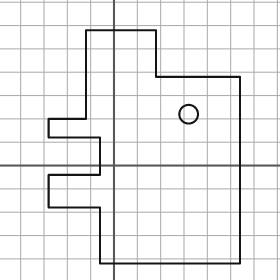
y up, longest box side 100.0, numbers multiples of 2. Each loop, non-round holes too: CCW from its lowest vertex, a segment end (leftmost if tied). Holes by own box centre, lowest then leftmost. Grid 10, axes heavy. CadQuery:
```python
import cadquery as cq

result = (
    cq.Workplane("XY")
    .moveTo(-6.0, -42.0)
    .lineTo(54.0, -42.0)
    .lineTo(54.0, 38.0)
    .lineTo(18.0, 38.0)
    .lineTo(18.0, 58.0)
    .lineTo(-12.0, 58.0)
    .lineTo(-12.0, 20.0)
    .lineTo(-28.0, 20.0)
    .lineTo(-28.0, 12.0)
    .lineTo(-6.0, 12.0)
    .lineTo(-6.0, -4.0)
    .lineTo(-28.0, -4.0)
    .lineTo(-28.0, -18.0)
    .lineTo(-6.0, -18.0)
    .close()
    .moveTo(32.0, 22.0)
    .circle(4.0)
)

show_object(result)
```